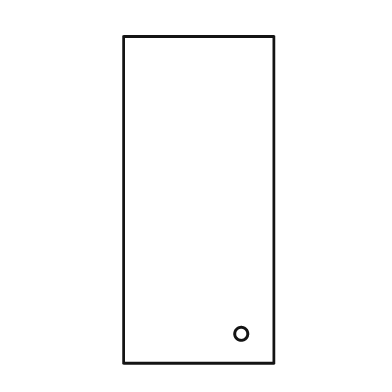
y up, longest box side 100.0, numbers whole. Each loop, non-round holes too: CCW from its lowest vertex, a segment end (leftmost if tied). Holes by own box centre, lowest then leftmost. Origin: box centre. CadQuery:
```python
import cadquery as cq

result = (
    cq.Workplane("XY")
    .moveTo(-23.0, -50.0)
    .lineTo(23.0, -50.0)
    .lineTo(23.0, 50.0)
    .lineTo(-23.0, 50.0)
    .close()
    .moveTo(13.0, -41.0)
    .circle(2.0)
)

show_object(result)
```